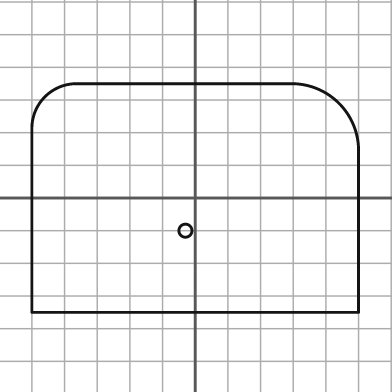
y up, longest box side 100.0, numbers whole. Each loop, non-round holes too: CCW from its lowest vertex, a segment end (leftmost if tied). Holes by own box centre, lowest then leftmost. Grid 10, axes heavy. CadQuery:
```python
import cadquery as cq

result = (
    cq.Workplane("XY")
    .moveTo(-50.0, -35.0)
    .lineTo(50.0, -35.0)
    .lineTo(50.0, 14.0)
    .threePointArc((44.0, 29.0), (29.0, 35.0))
    .lineTo(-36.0, 35.0)
    .threePointArc((-46.0, 31.0), (-50.0, 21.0))
    .close()
    .moveTo(-3.0, -10.0)
    .circle(2.0)
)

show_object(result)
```